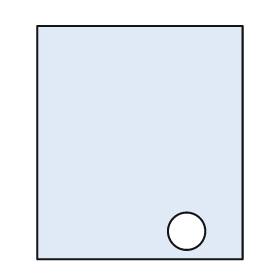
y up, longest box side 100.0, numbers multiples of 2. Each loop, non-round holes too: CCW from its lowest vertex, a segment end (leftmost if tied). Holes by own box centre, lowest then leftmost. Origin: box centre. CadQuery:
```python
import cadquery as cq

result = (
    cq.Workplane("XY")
    .moveTo(-44.0, -50.0)
    .lineTo(44.0, -50.0)
    .lineTo(44.0, 50.0)
    .lineTo(-44.0, 50.0)
    .close()
    .moveTo(20.0, -38.0)
    .circle(8.0)
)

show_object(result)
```